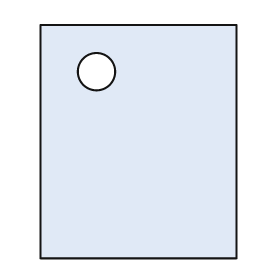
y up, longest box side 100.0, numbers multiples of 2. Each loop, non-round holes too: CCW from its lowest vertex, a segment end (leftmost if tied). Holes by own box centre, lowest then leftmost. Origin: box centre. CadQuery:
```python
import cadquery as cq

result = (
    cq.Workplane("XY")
    .moveTo(-42.0, -50.0)
    .lineTo(42.0, -50.0)
    .lineTo(42.0, 50.0)
    .lineTo(-42.0, 50.0)
    .close()
    .moveTo(-18.0, 30.0)
    .circle(8.0)
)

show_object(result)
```